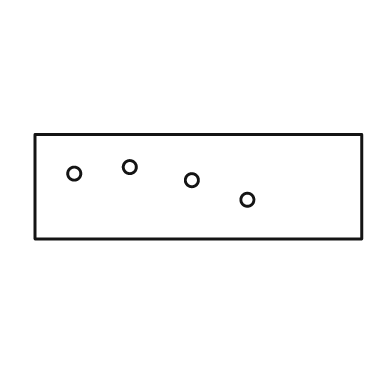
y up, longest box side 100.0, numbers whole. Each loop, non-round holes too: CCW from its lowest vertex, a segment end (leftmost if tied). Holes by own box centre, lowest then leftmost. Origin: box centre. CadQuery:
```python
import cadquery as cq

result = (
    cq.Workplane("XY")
    .moveTo(-50.0, -16.0)
    .lineTo(50.0, -16.0)
    .lineTo(50.0, 16.0)
    .lineTo(-50.0, 16.0)
    .close()
    .moveTo(15.0, -4.0)
    .circle(2.0)
    .moveTo(-2.0, 2.0)
    .circle(2.0)
    .moveTo(-38.0, 4.0)
    .circle(2.0)
    .moveTo(-21.0, 6.0)
    .circle(2.0)
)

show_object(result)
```